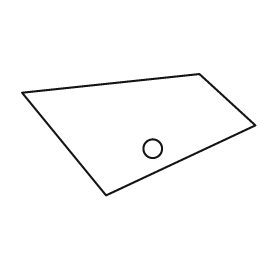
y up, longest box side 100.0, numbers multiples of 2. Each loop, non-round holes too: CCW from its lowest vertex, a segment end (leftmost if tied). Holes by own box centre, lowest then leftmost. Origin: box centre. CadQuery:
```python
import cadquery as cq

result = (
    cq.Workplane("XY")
    .moveTo(-14.0, -26.0)
    .lineTo(50.0, 4.0)
    .lineTo(26.0, 26.0)
    .lineTo(-50.0, 18.0)
    .close()
    .moveTo(6.0, -6.0)
    .circle(4.0)
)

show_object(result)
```